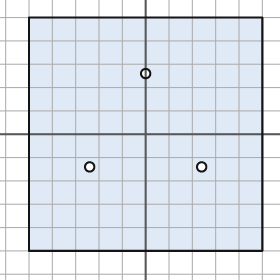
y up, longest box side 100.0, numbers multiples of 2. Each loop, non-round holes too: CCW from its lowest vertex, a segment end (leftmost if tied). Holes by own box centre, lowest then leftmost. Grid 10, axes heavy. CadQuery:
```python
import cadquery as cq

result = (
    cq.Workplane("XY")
    .moveTo(-50.0, -50.0)
    .lineTo(50.0, -50.0)
    .lineTo(50.0, 50.0)
    .lineTo(-50.0, 50.0)
    .close()
    .moveTo(-24.0, -14.0)
    .circle(2.0)
    .moveTo(24.0, -14.0)
    .circle(2.0)
    .moveTo(0.0, 26.0)
    .circle(2.0)
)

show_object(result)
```